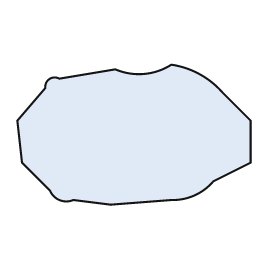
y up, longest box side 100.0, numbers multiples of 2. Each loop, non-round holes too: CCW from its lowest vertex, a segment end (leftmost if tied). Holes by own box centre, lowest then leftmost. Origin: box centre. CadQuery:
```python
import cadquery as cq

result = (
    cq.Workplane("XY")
    .moveTo(-10.0, -30.0)
    .lineTo(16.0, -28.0)
    .threePointArc((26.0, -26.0), (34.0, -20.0))
    .lineTo(50.0, -12.0)
    .lineTo(50.0, 6.0)
    .lineTo(38.0, 18.0)
    .threePointArc((28.0, 26.0), (16.0, 30.0))
    .threePointArc((4.0, 26.0), (-8.0, 28.0))
    .lineTo(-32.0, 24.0)
    .threePointArc((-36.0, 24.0), (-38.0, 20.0))
    .lineTo(-50.0, 6.0)
    .lineTo(-48.0, -12.0)
    .lineTo(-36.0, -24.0)
    .threePointArc((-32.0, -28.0), (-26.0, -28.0))
    .close()
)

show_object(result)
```